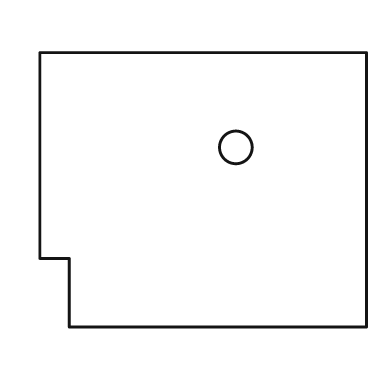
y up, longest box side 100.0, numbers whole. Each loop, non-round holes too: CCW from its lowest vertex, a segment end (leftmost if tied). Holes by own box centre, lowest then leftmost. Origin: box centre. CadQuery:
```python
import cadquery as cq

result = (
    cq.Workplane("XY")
    .moveTo(-41.0, -42.0)
    .lineTo(50.0, -42.0)
    .lineTo(50.0, 42.0)
    .lineTo(-50.0, 42.0)
    .lineTo(-50.0, -21.0)
    .lineTo(-41.0, -21.0)
    .close()
    .moveTo(10.0, 13.0)
    .circle(5.0)
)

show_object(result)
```